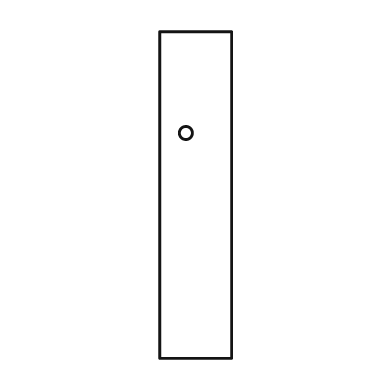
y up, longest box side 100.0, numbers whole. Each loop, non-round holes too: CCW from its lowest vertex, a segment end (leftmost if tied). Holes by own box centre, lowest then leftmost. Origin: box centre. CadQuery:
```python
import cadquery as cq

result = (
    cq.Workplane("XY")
    .moveTo(-11.0, -50.0)
    .lineTo(11.0, -50.0)
    .lineTo(11.0, 50.0)
    .lineTo(-11.0, 50.0)
    .close()
    .moveTo(-3.0, 19.0)
    .circle(2.0)
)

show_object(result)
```